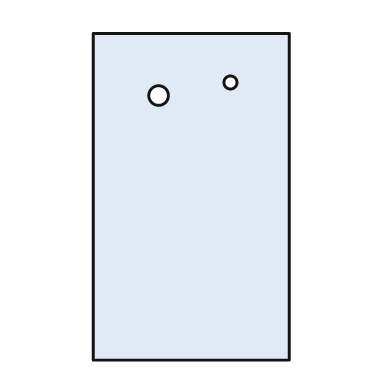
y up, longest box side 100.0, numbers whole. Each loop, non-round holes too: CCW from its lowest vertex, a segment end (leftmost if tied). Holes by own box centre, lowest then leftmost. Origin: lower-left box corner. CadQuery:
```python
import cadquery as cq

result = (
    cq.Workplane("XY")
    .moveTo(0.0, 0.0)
    .lineTo(60.0, 0.0)
    .lineTo(60.0, 100.0)
    .lineTo(0.0, 100.0)
    .close()
    .moveTo(20.0, 81.0)
    .circle(3.0)
    .moveTo(42.0, 85.0)
    .circle(2.0)
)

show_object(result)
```